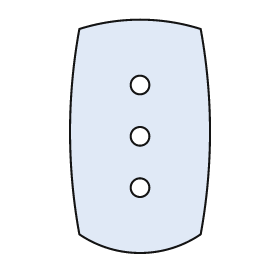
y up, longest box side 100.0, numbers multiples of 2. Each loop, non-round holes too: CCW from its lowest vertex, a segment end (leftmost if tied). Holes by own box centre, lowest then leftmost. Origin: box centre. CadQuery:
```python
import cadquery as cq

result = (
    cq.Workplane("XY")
    .moveTo(-26.0, -42.0)
    .threePointArc((0.0, -50.0), (26.0, -42.0))
    .threePointArc((30.0, 2.0), (26.0, 46.0))
    .threePointArc((0.0, 50.0), (-26.0, 46.0))
    .threePointArc((-30.0, 2.0), (-26.0, -42.0))
    .close()
    .moveTo(0.0, -22.0)
    .circle(4.0)
    .moveTo(0.0, 0.0)
    .circle(4.0)
    .moveTo(0.0, 22.0)
    .circle(4.0)
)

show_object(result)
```